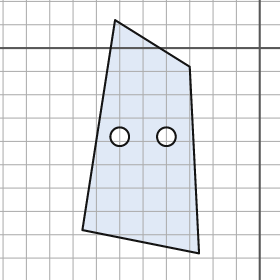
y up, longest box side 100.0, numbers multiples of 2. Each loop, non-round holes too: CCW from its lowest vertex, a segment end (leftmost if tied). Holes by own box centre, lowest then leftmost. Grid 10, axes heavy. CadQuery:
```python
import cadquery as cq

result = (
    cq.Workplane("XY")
    .moveTo(-26.0, -88.0)
    .lineTo(-30.0, -8.0)
    .lineTo(-62.0, 12.0)
    .lineTo(-76.0, -78.0)
    .close()
    .moveTo(-60.0, -38.0)
    .circle(4.0)
    .moveTo(-40.0, -38.0)
    .circle(4.0)
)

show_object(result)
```